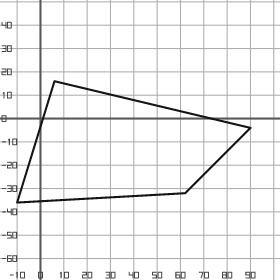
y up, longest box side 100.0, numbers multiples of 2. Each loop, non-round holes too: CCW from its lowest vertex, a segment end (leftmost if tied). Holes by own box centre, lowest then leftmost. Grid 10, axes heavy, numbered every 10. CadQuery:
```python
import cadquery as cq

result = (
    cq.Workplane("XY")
    .moveTo(-10.0, -36.0)
    .lineTo(62.0, -32.0)
    .lineTo(90.0, -4.0)
    .lineTo(6.0, 16.0)
    .close()
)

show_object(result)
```